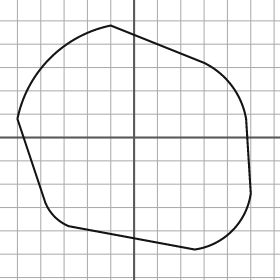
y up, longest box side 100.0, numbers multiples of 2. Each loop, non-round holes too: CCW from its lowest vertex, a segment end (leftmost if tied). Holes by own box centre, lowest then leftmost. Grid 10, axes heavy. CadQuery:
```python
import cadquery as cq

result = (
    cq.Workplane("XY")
    .moveTo(26.0, -48.0)
    .threePointArc((42.0, -40.0), (50.0, -24.0))
    .lineTo(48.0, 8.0)
    .threePointArc((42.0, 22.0), (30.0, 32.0))
    .lineTo(-10.0, 48.0)
    .threePointArc((-36.0, 34.0), (-50.0, 8.0))
    .lineTo(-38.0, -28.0)
    .threePointArc((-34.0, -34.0), (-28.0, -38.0))
    .close()
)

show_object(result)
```